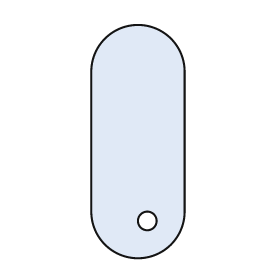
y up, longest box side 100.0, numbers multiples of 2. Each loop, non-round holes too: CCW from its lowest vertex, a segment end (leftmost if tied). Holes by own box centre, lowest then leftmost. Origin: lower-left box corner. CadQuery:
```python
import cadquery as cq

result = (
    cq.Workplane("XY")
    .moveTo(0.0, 20.0)
    .threePointArc((20.0, 0.0), (40.0, 20.0))
    .lineTo(40.0, 80.0)
    .threePointArc((20.0, 100.0), (0.0, 80.0))
    .close()
    .moveTo(24.0, 16.0)
    .circle(4.0)
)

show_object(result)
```